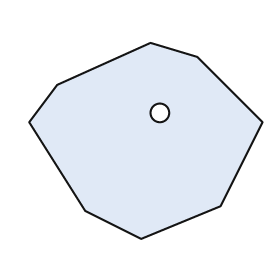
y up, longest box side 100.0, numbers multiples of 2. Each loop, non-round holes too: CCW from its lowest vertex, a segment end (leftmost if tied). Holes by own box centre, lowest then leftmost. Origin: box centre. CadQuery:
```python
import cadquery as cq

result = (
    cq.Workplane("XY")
    .moveTo(-2.0, -42.0)
    .lineTo(32.0, -28.0)
    .lineTo(50.0, 8.0)
    .lineTo(22.0, 36.0)
    .lineTo(2.0, 42.0)
    .lineTo(-38.0, 24.0)
    .lineTo(-50.0, 8.0)
    .lineTo(-26.0, -30.0)
    .close()
    .moveTo(6.0, 12.0)
    .circle(4.0)
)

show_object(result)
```